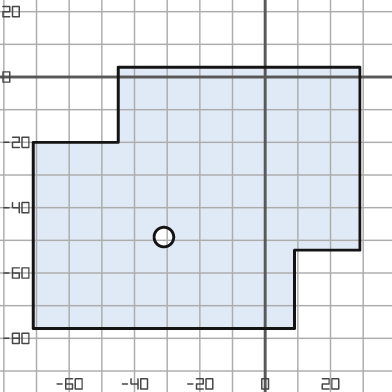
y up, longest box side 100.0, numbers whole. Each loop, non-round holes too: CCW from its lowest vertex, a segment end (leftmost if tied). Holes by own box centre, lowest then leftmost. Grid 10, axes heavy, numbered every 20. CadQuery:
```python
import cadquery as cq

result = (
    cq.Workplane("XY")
    .moveTo(-71.0, -77.0)
    .lineTo(9.0, -77.0)
    .lineTo(9.0, -53.0)
    .lineTo(29.0, -53.0)
    .lineTo(29.0, 3.0)
    .lineTo(-45.0, 3.0)
    .lineTo(-45.0, -20.0)
    .lineTo(-71.0, -20.0)
    .close()
    .moveTo(-31.0, -49.0)
    .circle(3.0)
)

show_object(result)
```